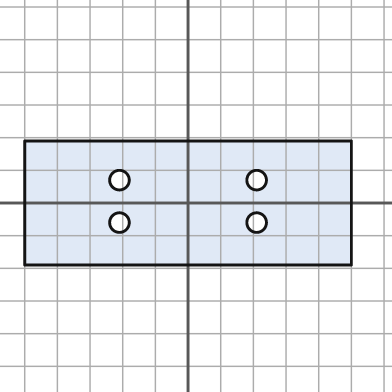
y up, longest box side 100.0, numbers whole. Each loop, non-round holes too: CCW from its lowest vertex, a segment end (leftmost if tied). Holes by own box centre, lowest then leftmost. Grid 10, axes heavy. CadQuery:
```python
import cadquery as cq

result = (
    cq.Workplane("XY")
    .moveTo(-50.0, -19.0)
    .lineTo(50.0, -19.0)
    .lineTo(50.0, 19.0)
    .lineTo(-50.0, 19.0)
    .close()
    .moveTo(-21.0, -6.0)
    .circle(3.0)
    .moveTo(21.0, -6.0)
    .circle(3.0)
    .moveTo(-21.0, 7.0)
    .circle(3.0)
    .moveTo(21.0, 7.0)
    .circle(3.0)
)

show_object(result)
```